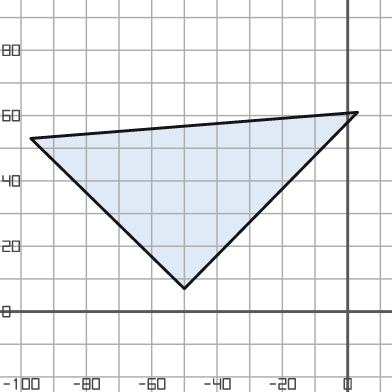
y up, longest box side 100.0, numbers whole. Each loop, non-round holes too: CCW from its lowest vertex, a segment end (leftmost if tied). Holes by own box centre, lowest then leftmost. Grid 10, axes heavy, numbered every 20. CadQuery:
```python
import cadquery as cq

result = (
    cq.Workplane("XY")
    .moveTo(-50.0, 7.0)
    .lineTo(3.0, 61.0)
    .lineTo(-97.0, 53.0)
    .close()
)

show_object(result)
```